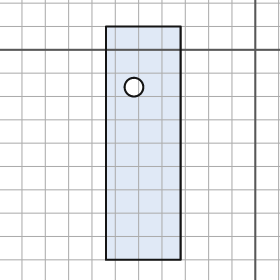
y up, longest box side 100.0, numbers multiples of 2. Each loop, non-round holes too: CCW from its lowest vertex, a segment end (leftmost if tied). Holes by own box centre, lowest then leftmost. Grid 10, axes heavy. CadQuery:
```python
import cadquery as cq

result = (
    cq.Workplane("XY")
    .moveTo(-64.0, -90.0)
    .lineTo(-32.0, -90.0)
    .lineTo(-32.0, 10.0)
    .lineTo(-64.0, 10.0)
    .close()
    .moveTo(-52.0, -16.0)
    .circle(4.0)
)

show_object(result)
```